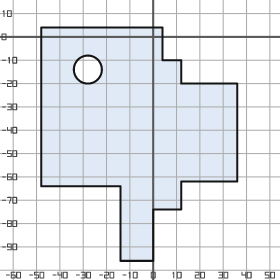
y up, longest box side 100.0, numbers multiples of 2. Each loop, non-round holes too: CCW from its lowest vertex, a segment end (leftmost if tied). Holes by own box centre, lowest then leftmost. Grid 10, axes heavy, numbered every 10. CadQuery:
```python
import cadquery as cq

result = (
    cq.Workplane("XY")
    .moveTo(-14.0, -96.0)
    .lineTo(0.0, -96.0)
    .lineTo(0.0, -74.0)
    .lineTo(12.0, -74.0)
    .lineTo(12.0, -62.0)
    .lineTo(36.0, -62.0)
    .lineTo(36.0, -20.0)
    .lineTo(12.0, -20.0)
    .lineTo(12.0, -10.0)
    .lineTo(4.0, -10.0)
    .lineTo(4.0, 4.0)
    .lineTo(-48.0, 4.0)
    .lineTo(-48.0, -64.0)
    .lineTo(-14.0, -64.0)
    .close()
    .moveTo(-28.0, -14.0)
    .circle(6.0)
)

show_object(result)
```